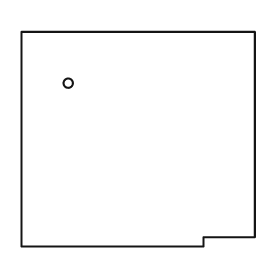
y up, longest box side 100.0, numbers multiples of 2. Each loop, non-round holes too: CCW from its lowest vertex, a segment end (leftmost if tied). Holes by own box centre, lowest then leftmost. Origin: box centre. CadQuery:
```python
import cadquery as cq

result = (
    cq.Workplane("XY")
    .moveTo(-50.0, -46.0)
    .lineTo(28.0, -46.0)
    .lineTo(28.0, -42.0)
    .lineTo(50.0, -42.0)
    .lineTo(50.0, 46.0)
    .lineTo(-50.0, 46.0)
    .close()
    .moveTo(-30.0, 24.0)
    .circle(2.0)
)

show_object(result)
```